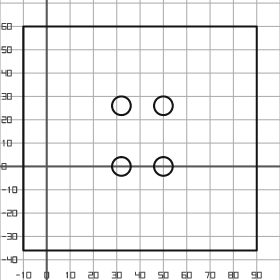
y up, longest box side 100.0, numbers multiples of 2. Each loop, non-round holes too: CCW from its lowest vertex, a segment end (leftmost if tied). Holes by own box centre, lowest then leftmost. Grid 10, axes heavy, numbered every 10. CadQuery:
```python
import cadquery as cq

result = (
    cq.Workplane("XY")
    .moveTo(-10.0, -36.0)
    .lineTo(90.0, -36.0)
    .lineTo(90.0, 60.0)
    .lineTo(-10.0, 60.0)
    .close()
    .moveTo(32.0, 0.0)
    .circle(4.0)
    .moveTo(50.0, 0.0)
    .circle(4.0)
    .moveTo(32.0, 26.0)
    .circle(4.0)
    .moveTo(50.0, 26.0)
    .circle(4.0)
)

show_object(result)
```